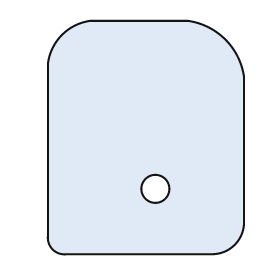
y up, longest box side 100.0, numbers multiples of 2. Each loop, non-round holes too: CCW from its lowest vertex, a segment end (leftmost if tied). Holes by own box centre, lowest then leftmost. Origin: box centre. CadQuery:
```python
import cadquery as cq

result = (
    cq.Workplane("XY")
    .moveTo(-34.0, -50.0)
    .lineTo(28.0, -50.0)
    .threePointArc((38.0, -46.0), (42.0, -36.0))
    .lineTo(42.0, 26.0)
    .threePointArc((34.0, 42.0), (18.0, 50.0))
    .lineTo(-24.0, 50.0)
    .threePointArc((-36.0, 44.0), (-42.0, 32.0))
    .lineTo(-42.0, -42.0)
    .threePointArc((-40.0, -48.0), (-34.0, -50.0))
    .close()
    .moveTo(4.0, -22.0)
    .circle(6.0)
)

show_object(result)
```